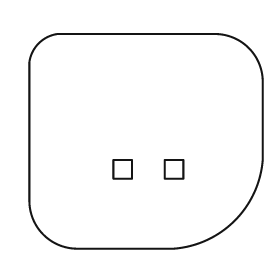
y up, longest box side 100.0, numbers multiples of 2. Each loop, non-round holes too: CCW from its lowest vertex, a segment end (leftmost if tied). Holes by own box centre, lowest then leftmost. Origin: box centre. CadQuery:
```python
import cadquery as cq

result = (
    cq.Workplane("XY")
    .moveTo(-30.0, -46.0)
    .lineTo(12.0, -46.0)
    .threePointArc((38.0, -34.0), (50.0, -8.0))
    .lineTo(50.0, 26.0)
    .threePointArc((44.0, 40.0), (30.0, 46.0))
    .lineTo(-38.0, 46.0)
    .threePointArc((-46.0, 42.0), (-50.0, 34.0))
    .lineTo(-50.0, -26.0)
    .threePointArc((-44.0, -40.0), (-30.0, -46.0))
    .close()
    .moveTo(-14.0, -16.0)
    .lineTo(-6.0, -16.0)
    .lineTo(-6.0, -8.0)
    .lineTo(-14.0, -8.0)
    .close()
    .moveTo(8.0, -16.0)
    .lineTo(16.0, -16.0)
    .lineTo(16.0, -8.0)
    .lineTo(8.0, -8.0)
    .close()
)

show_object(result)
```